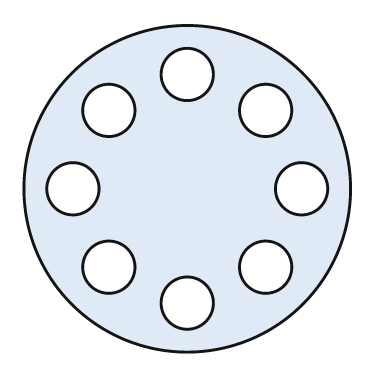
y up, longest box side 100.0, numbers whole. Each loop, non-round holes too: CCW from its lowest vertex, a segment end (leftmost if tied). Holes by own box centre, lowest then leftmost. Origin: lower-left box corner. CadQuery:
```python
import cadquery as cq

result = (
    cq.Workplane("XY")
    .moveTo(50.0, 50.0)
    .circle(50.0)
    .moveTo(50.0, 15.0)
    .circle(8.0)
    .moveTo(26.0, 26.0)
    .circle(8.0)
    .moveTo(74.0, 26.0)
    .circle(8.0)
    .moveTo(15.0, 50.0)
    .circle(8.0)
    .moveTo(85.0, 50.0)
    .circle(8.0)
    .moveTo(26.0, 74.0)
    .circle(8.0)
    .moveTo(74.0, 74.0)
    .circle(8.0)
    .moveTo(50.0, 85.0)
    .circle(8.0)
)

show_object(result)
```